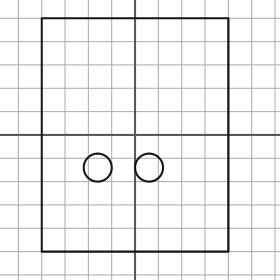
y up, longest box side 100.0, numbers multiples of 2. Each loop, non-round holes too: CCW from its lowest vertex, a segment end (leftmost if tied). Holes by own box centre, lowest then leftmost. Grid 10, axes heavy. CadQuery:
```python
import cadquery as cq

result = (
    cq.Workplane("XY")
    .moveTo(-40.0, -50.0)
    .lineTo(40.0, -50.0)
    .lineTo(40.0, 50.0)
    .lineTo(-40.0, 50.0)
    .close()
    .moveTo(-16.0, -14.0)
    .circle(6.0)
    .moveTo(6.0, -14.0)
    .circle(6.0)
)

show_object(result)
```